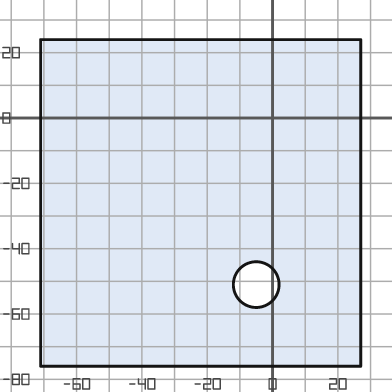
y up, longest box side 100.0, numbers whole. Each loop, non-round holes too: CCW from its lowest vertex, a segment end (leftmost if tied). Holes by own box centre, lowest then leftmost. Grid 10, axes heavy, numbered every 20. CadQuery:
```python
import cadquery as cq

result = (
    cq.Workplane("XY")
    .moveTo(-71.0, -76.0)
    .lineTo(27.0, -76.0)
    .lineTo(27.0, 24.0)
    .lineTo(-71.0, 24.0)
    .close()
    .moveTo(-5.0, -51.0)
    .circle(7.0)
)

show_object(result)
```